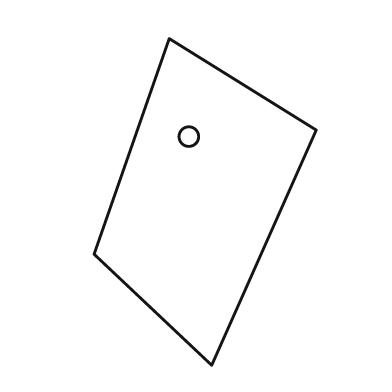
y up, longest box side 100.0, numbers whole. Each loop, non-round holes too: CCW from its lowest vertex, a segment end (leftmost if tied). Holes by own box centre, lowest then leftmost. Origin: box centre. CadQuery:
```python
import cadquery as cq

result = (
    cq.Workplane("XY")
    .moveTo(2.0, -50.0)
    .lineTo(34.0, 22.0)
    .lineTo(-11.0, 50.0)
    .lineTo(-34.0, -16.0)
    .close()
    .moveTo(-5.0, 20.0)
    .circle(3.0)
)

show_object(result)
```